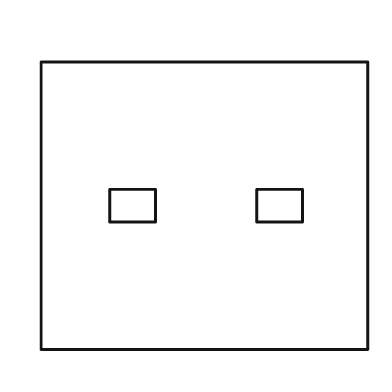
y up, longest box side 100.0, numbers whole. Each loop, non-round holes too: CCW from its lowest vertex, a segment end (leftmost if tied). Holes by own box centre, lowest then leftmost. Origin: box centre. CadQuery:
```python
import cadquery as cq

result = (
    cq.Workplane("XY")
    .moveTo(-50.0, -44.0)
    .lineTo(50.0, -44.0)
    .lineTo(50.0, 44.0)
    .lineTo(-50.0, 44.0)
    .close()
    .moveTo(-29.0, -5.0)
    .lineTo(-15.0, -5.0)
    .lineTo(-15.0, 5.0)
    .lineTo(-29.0, 5.0)
    .close()
    .moveTo(16.0, -5.0)
    .lineTo(30.0, -5.0)
    .lineTo(30.0, 5.0)
    .lineTo(16.0, 5.0)
    .close()
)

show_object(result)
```